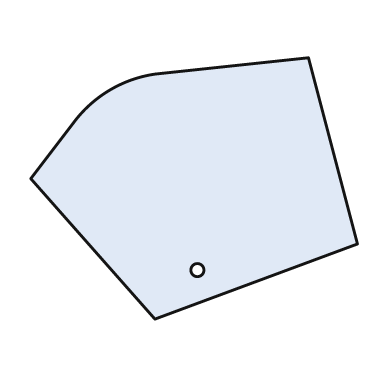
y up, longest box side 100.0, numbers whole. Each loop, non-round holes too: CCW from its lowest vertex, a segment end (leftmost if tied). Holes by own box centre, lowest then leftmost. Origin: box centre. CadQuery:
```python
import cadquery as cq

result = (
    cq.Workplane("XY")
    .moveTo(-12.0, -40.0)
    .lineTo(50.0, -17.0)
    .lineTo(35.0, 40.0)
    .lineTo(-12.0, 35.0)
    .threePointArc((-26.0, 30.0), (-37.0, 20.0))
    .lineTo(-50.0, 3.0)
    .close()
    .moveTo(1.0, -25.0)
    .circle(2.0)
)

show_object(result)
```